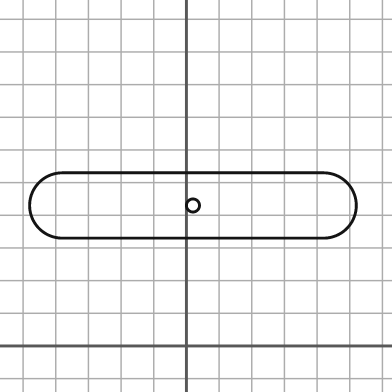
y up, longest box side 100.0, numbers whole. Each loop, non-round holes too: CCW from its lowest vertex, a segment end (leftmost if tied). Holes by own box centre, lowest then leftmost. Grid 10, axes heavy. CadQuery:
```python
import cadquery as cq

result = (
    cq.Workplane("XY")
    .moveTo(-38.0, 33.0)
    .lineTo(42.0, 33.0)
    .threePointArc((52.0, 43.0), (42.0, 53.0))
    .lineTo(-38.0, 53.0)
    .threePointArc((-48.0, 43.0), (-38.0, 33.0))
    .close()
    .moveTo(2.0, 43.0)
    .circle(2.0)
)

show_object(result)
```